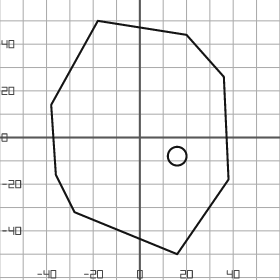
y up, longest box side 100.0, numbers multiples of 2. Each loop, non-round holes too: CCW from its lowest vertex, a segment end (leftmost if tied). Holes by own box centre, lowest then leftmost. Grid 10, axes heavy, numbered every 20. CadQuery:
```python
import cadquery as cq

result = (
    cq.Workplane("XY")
    .moveTo(16.0, -50.0)
    .lineTo(38.0, -18.0)
    .lineTo(36.0, 26.0)
    .lineTo(20.0, 44.0)
    .lineTo(-18.0, 50.0)
    .lineTo(-38.0, 14.0)
    .lineTo(-36.0, -16.0)
    .lineTo(-28.0, -32.0)
    .close()
    .moveTo(16.0, -8.0)
    .circle(4.0)
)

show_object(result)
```